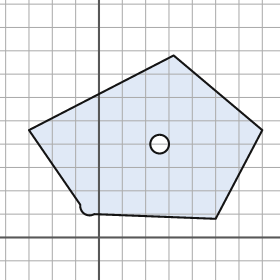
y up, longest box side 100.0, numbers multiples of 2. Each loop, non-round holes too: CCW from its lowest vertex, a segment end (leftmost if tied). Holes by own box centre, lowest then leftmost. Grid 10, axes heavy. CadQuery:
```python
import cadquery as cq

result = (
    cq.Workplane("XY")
    .moveTo(50.0, 8.0)
    .lineTo(70.0, 46.0)
    .lineTo(32.0, 78.0)
    .lineTo(-30.0, 46.0)
    .lineTo(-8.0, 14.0)
    .threePointArc((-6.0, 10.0), (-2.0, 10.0))
    .close()
    .moveTo(26.0, 40.0)
    .circle(4.0)
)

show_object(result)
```